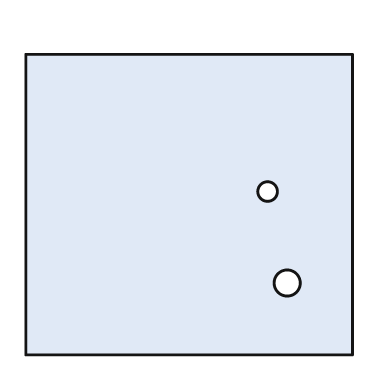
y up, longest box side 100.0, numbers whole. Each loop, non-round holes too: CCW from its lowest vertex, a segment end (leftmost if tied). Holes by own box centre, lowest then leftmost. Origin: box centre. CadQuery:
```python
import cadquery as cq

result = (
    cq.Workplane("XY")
    .moveTo(-50.0, -46.0)
    .lineTo(50.0, -46.0)
    .lineTo(50.0, 46.0)
    .lineTo(-50.0, 46.0)
    .close()
    .moveTo(30.0, -24.0)
    .circle(4.0)
    .moveTo(24.0, 4.0)
    .circle(3.0)
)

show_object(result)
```